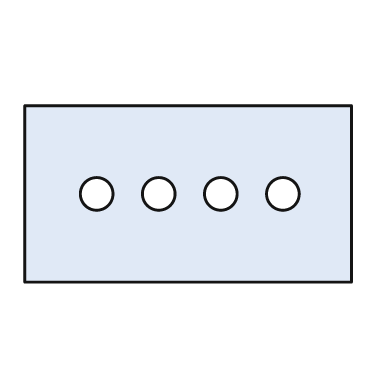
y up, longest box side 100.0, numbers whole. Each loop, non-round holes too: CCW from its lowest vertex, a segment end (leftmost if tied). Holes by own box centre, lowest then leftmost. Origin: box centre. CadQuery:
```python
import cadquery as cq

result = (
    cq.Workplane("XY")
    .moveTo(-50.0, -27.0)
    .lineTo(50.0, -27.0)
    .lineTo(50.0, 27.0)
    .lineTo(-50.0, 27.0)
    .close()
    .moveTo(-28.0, 0.0)
    .circle(5.0)
    .moveTo(-9.0, 0.0)
    .circle(5.0)
    .moveTo(10.0, 0.0)
    .circle(5.0)
    .moveTo(29.0, 0.0)
    .circle(5.0)
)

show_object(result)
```